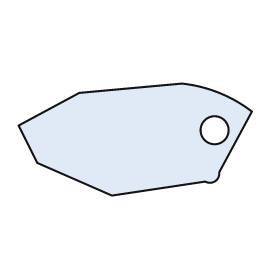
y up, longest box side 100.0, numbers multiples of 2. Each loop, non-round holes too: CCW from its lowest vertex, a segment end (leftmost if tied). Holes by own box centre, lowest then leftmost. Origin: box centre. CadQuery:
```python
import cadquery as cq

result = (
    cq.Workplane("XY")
    .moveTo(-10.0, -24.0)
    .lineTo(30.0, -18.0)
    .threePointArc((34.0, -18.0), (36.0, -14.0))
    .lineTo(50.0, 12.0)
    .threePointArc((36.0, 20.0), (20.0, 24.0))
    .lineTo(-24.0, 20.0)
    .lineTo(-50.0, 6.0)
    .lineTo(-42.0, -10.0)
    .close()
    .moveTo(34.0, 4.0)
    .circle(6.0)
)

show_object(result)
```